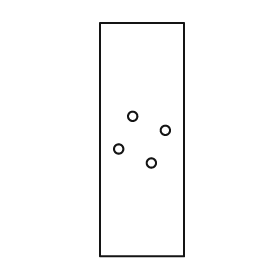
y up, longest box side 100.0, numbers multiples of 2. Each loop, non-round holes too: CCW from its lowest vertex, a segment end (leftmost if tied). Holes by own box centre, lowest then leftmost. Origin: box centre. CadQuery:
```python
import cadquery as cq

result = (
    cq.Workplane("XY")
    .moveTo(-18.0, -50.0)
    .lineTo(18.0, -50.0)
    .lineTo(18.0, 50.0)
    .lineTo(-18.0, 50.0)
    .close()
    .moveTo(4.0, -10.0)
    .circle(2.0)
    .moveTo(-10.0, -4.0)
    .circle(2.0)
    .moveTo(10.0, 4.0)
    .circle(2.0)
    .moveTo(-4.0, 10.0)
    .circle(2.0)
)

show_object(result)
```